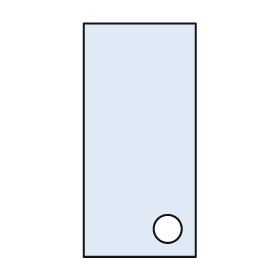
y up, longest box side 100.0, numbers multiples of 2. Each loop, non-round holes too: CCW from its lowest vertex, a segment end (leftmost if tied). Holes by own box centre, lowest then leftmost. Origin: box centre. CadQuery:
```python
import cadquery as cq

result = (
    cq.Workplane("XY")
    .moveTo(-24.0, -50.0)
    .lineTo(24.0, -50.0)
    .lineTo(24.0, 50.0)
    .lineTo(-24.0, 50.0)
    .close()
    .moveTo(12.0, -38.0)
    .circle(6.0)
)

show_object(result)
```